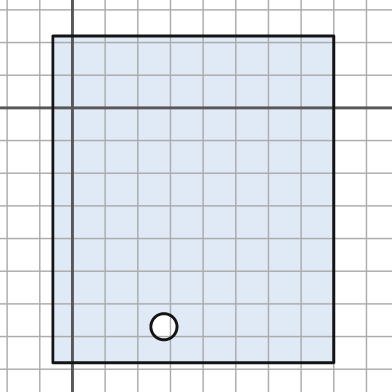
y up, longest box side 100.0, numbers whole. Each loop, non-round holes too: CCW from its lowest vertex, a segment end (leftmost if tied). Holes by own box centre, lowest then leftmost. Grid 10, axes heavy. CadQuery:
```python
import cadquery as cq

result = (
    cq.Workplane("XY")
    .moveTo(-6.0, -78.0)
    .lineTo(80.0, -78.0)
    .lineTo(80.0, 22.0)
    .lineTo(-6.0, 22.0)
    .close()
    .moveTo(28.0, -67.0)
    .circle(4.0)
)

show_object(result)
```